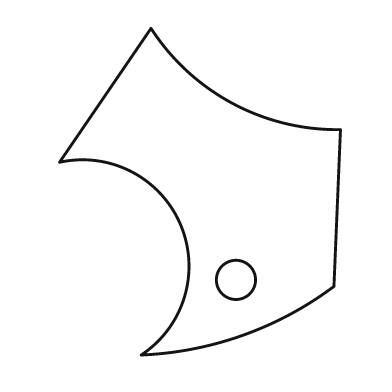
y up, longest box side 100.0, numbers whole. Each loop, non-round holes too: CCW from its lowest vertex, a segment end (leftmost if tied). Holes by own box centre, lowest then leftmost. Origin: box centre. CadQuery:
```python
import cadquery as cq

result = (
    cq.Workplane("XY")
    .moveTo(-18.0, -50.0)
    .threePointArc((13.0, -44.0), (41.0, -29.0))
    .lineTo(43.0, 19.0)
    .threePointArc((10.0, 27.0), (-15.0, 50.0))
    .lineTo(-43.0, 9.0)
    .threePointArc((-6.0, -10.0), (-18.0, -50.0))
    .close()
    .moveTo(11.0, -27.0)
    .circle(6.0)
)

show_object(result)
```